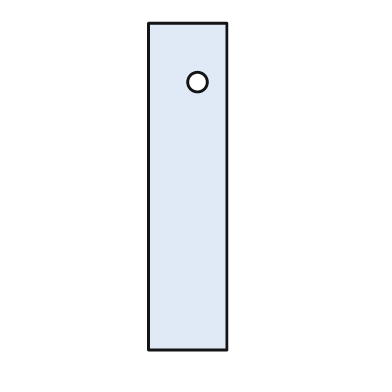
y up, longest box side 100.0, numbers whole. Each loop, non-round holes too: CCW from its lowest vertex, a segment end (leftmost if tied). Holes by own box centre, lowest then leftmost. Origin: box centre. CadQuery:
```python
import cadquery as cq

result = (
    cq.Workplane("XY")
    .moveTo(-12.0, -50.0)
    .lineTo(12.0, -50.0)
    .lineTo(12.0, 50.0)
    .lineTo(-12.0, 50.0)
    .close()
    .moveTo(3.0, 32.0)
    .circle(3.0)
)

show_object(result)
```